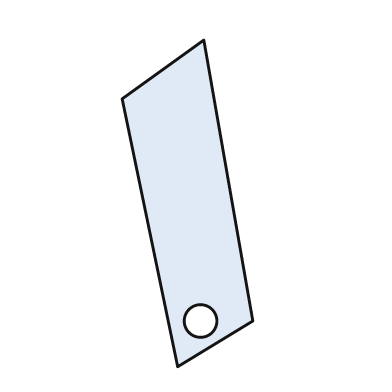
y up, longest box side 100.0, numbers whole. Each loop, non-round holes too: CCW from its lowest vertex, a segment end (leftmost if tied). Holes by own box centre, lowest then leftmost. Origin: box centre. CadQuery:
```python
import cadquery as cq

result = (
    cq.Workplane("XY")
    .moveTo(-3.0, -50.0)
    .lineTo(20.0, -36.0)
    .lineTo(5.0, 50.0)
    .lineTo(-20.0, 32.0)
    .close()
    .moveTo(4.0, -36.0)
    .circle(5.0)
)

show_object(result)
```